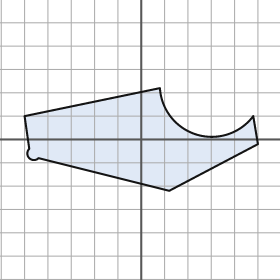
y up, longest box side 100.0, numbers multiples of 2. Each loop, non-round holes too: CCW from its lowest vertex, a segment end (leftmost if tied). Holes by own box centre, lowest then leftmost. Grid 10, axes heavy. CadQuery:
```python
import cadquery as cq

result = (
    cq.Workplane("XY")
    .moveTo(12.0, -22.0)
    .lineTo(50.0, -2.0)
    .lineTo(48.0, 10.0)
    .threePointArc((24.0, 2.0), (8.0, 22.0))
    .lineTo(-50.0, 10.0)
    .lineTo(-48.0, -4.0)
    .threePointArc((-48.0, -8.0), (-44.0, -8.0))
    .close()
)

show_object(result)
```